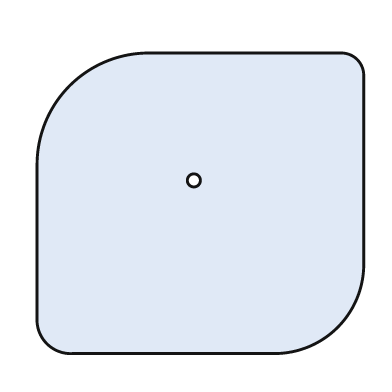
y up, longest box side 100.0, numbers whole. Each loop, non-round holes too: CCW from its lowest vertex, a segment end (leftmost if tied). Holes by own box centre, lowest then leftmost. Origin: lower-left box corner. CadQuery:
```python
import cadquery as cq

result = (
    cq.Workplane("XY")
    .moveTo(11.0, 0.0)
    .lineTo(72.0, 0.0)
    .threePointArc((92.0, 8.0), (100.0, 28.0))
    .lineTo(100.0, 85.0)
    .threePointArc((98.0, 90.0), (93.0, 92.0))
    .lineTo(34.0, 92.0)
    .threePointArc((10.0, 82.0), (0.0, 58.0))
    .lineTo(0.0, 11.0)
    .threePointArc((3.0, 3.0), (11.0, 0.0))
    .close()
    .moveTo(48.0, 53.0)
    .circle(2.0)
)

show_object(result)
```